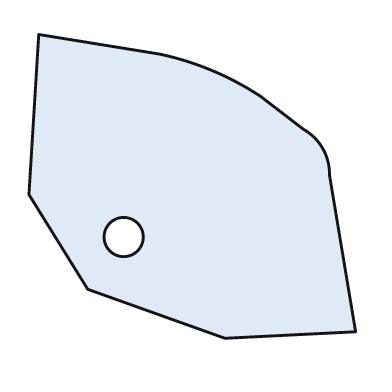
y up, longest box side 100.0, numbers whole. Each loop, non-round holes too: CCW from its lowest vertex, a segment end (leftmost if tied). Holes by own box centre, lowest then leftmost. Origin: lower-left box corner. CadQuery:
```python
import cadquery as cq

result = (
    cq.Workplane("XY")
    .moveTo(60.0, 0.0)
    .lineTo(100.0, 2.0)
    .lineTo(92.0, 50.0)
    .threePointArc((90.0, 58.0), (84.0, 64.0))
    .lineTo(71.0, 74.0)
    .threePointArc((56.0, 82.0), (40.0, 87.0))
    .lineTo(3.0, 93.0)
    .lineTo(0.0, 44.0)
    .lineTo(18.0, 15.0)
    .close()
    .moveTo(29.0, 31.0)
    .circle(6.0)
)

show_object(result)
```